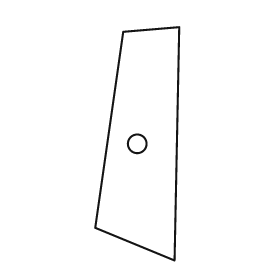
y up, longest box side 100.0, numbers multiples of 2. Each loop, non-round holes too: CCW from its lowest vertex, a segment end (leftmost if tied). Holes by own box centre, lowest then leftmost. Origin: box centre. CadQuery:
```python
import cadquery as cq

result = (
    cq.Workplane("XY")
    .moveTo(16.0, -50.0)
    .lineTo(18.0, 50.0)
    .lineTo(-6.0, 48.0)
    .lineTo(-18.0, -36.0)
    .close()
    .moveTo(0.0, 0.0)
    .circle(4.0)
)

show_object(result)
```